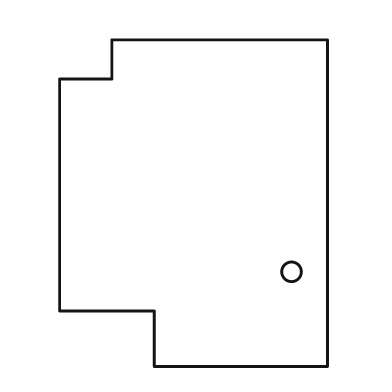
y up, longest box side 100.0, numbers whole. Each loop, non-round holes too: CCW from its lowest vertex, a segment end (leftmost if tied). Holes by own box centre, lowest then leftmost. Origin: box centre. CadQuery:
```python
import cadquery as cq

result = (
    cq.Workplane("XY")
    .moveTo(-12.0, -50.0)
    .lineTo(41.0, -50.0)
    .lineTo(41.0, 50.0)
    .lineTo(-25.0, 50.0)
    .lineTo(-25.0, 38.0)
    .lineTo(-41.0, 38.0)
    .lineTo(-41.0, -33.0)
    .lineTo(-12.0, -33.0)
    .close()
    .moveTo(30.0, -21.0)
    .circle(3.0)
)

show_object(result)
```